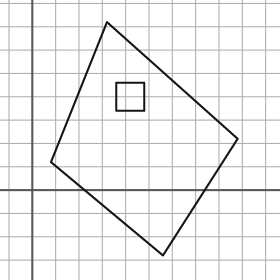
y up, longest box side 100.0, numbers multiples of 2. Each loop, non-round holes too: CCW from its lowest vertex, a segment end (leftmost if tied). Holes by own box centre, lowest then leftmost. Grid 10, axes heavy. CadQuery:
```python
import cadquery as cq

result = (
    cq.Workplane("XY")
    .moveTo(56.0, -28.0)
    .lineTo(88.0, 22.0)
    .lineTo(32.0, 72.0)
    .lineTo(8.0, 12.0)
    .close()
    .moveTo(36.0, 34.0)
    .lineTo(48.0, 34.0)
    .lineTo(48.0, 46.0)
    .lineTo(36.0, 46.0)
    .close()
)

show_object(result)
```